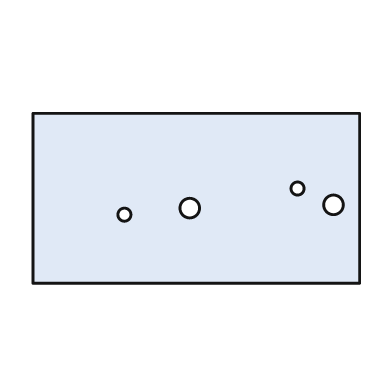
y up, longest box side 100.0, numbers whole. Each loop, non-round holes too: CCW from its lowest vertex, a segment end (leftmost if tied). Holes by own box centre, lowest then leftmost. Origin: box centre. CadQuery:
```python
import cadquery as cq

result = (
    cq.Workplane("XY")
    .moveTo(-50.0, -26.0)
    .lineTo(50.0, -26.0)
    .lineTo(50.0, 26.0)
    .lineTo(-50.0, 26.0)
    .close()
    .moveTo(-22.0, -5.0)
    .circle(2.0)
    .moveTo(-2.0, -3.0)
    .circle(3.0)
    .moveTo(42.0, -2.0)
    .circle(3.0)
    .moveTo(31.0, 3.0)
    .circle(2.0)
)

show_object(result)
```